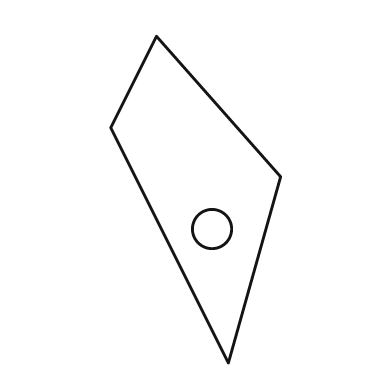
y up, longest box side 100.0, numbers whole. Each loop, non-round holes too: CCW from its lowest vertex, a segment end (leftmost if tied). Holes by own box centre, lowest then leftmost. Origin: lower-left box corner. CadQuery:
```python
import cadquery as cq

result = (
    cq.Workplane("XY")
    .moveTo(36.0, 0.0)
    .lineTo(52.0, 57.0)
    .lineTo(14.0, 100.0)
    .lineTo(0.0, 72.0)
    .close()
    .moveTo(31.0, 41.0)
    .circle(6.0)
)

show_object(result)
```